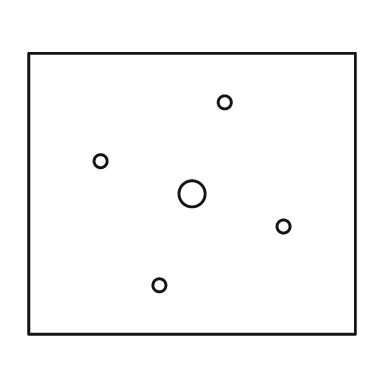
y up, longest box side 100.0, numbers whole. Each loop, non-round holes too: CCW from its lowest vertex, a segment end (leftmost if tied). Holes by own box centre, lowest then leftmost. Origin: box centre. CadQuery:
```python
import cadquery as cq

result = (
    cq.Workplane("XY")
    .moveTo(-50.0, -43.0)
    .lineTo(50.0, -43.0)
    .lineTo(50.0, 43.0)
    .lineTo(-50.0, 43.0)
    .close()
    .moveTo(-10.0, -28.0)
    .circle(2.0)
    .moveTo(28.0, -10.0)
    .circle(2.0)
    .moveTo(0.0, 0.0)
    .circle(4.0)
    .moveTo(-28.0, 10.0)
    .circle(2.0)
    .moveTo(10.0, 28.0)
    .circle(2.0)
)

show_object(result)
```